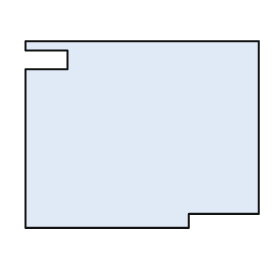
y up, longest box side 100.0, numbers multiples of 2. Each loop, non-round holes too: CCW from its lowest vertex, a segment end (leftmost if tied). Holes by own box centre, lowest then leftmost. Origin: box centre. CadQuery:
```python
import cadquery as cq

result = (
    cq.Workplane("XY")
    .moveTo(-50.0, -40.0)
    .lineTo(20.0, -40.0)
    .lineTo(20.0, -34.0)
    .lineTo(50.0, -34.0)
    .lineTo(50.0, 40.0)
    .lineTo(-50.0, 40.0)
    .lineTo(-50.0, 36.0)
    .lineTo(-32.0, 36.0)
    .lineTo(-32.0, 28.0)
    .lineTo(-50.0, 28.0)
    .close()
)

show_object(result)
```